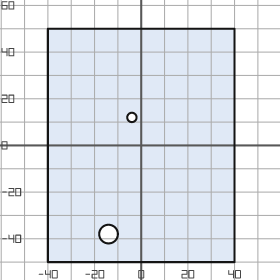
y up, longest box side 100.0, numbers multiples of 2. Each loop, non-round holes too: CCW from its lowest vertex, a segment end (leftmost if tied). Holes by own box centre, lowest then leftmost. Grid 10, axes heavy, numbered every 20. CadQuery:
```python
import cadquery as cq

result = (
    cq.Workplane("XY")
    .moveTo(-40.0, -50.0)
    .lineTo(40.0, -50.0)
    .lineTo(40.0, 50.0)
    .lineTo(-40.0, 50.0)
    .close()
    .moveTo(-14.0, -38.0)
    .circle(4.0)
    .moveTo(-4.0, 12.0)
    .circle(2.0)
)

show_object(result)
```